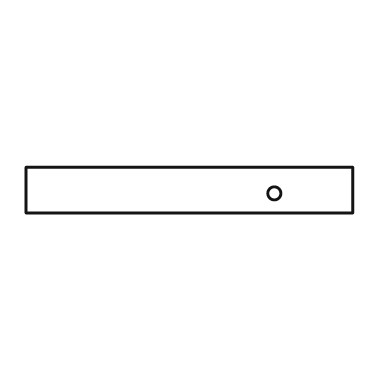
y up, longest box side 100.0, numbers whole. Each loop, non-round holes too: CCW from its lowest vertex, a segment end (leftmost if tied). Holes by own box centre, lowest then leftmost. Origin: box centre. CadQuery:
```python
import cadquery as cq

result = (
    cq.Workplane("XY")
    .moveTo(-50.0, -7.0)
    .lineTo(50.0, -7.0)
    .lineTo(50.0, 7.0)
    .lineTo(-50.0, 7.0)
    .close()
    .moveTo(26.0, -1.0)
    .circle(2.0)
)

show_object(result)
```